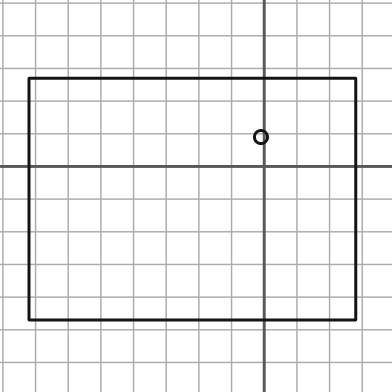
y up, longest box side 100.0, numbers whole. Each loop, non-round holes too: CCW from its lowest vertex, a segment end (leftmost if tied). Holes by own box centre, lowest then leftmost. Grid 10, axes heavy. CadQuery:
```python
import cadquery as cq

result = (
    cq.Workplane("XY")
    .moveTo(-72.0, -47.0)
    .lineTo(28.0, -47.0)
    .lineTo(28.0, 27.0)
    .lineTo(-72.0, 27.0)
    .close()
    .moveTo(-1.0, 9.0)
    .circle(2.0)
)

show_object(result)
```